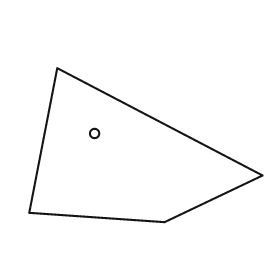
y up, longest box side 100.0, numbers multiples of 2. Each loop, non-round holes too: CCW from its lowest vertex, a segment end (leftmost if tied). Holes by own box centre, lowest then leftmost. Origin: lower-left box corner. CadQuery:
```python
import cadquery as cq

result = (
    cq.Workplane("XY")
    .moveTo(58.0, 0.0)
    .lineTo(100.0, 20.0)
    .lineTo(12.0, 66.0)
    .lineTo(0.0, 4.0)
    .close()
    .moveTo(28.0, 38.0)
    .circle(2.0)
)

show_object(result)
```